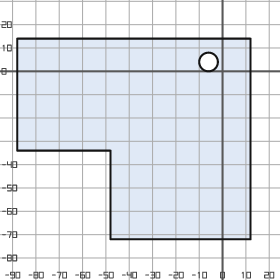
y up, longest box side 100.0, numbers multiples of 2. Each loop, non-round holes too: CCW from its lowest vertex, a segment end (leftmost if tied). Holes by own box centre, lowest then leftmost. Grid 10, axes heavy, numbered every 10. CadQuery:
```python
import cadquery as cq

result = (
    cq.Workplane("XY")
    .moveTo(-48.0, -72.0)
    .lineTo(12.0, -72.0)
    .lineTo(12.0, 14.0)
    .lineTo(-88.0, 14.0)
    .lineTo(-88.0, -34.0)
    .lineTo(-48.0, -34.0)
    .close()
    .moveTo(-6.0, 4.0)
    .circle(4.0)
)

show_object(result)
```